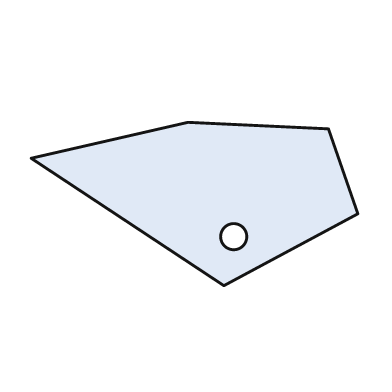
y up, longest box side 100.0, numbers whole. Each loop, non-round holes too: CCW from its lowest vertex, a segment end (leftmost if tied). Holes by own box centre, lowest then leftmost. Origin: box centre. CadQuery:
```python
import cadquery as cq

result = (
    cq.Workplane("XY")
    .moveTo(9.0, -25.0)
    .lineTo(50.0, -3.0)
    .lineTo(41.0, 23.0)
    .lineTo(-2.0, 25.0)
    .lineTo(-50.0, 14.0)
    .close()
    .moveTo(12.0, -10.0)
    .circle(4.0)
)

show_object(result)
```